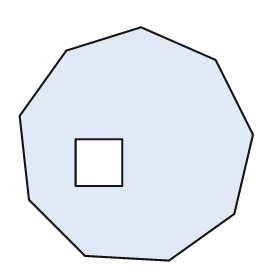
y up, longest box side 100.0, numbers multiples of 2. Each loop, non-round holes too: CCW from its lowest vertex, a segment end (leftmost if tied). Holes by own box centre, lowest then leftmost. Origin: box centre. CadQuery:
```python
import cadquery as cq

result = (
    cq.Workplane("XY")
    .moveTo(14.0, -50.0)
    .lineTo(42.0, -30.0)
    .lineTo(50.0, 4.0)
    .lineTo(34.0, 36.0)
    .lineTo(2.0, 50.0)
    .lineTo(-30.0, 40.0)
    .lineTo(-50.0, 12.0)
    .lineTo(-46.0, -24.0)
    .lineTo(-22.0, -48.0)
    .close()
    .moveTo(-26.0, -18.0)
    .lineTo(-6.0, -18.0)
    .lineTo(-6.0, 2.0)
    .lineTo(-26.0, 2.0)
    .close()
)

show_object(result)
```